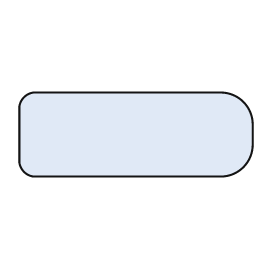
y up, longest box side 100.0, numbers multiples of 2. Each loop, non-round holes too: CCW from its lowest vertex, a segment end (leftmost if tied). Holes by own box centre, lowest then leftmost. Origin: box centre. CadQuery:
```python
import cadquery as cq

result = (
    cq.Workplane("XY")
    .moveTo(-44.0, -18.0)
    .lineTo(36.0, -18.0)
    .threePointArc((46.0, -14.0), (50.0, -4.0))
    .lineTo(50.0, 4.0)
    .threePointArc((46.0, 14.0), (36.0, 18.0))
    .lineTo(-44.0, 18.0)
    .threePointArc((-48.0, 16.0), (-50.0, 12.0))
    .lineTo(-50.0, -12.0)
    .threePointArc((-48.0, -16.0), (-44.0, -18.0))
    .close()
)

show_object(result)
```